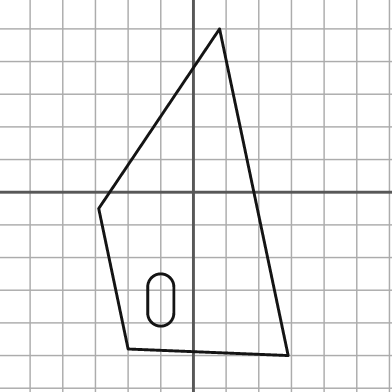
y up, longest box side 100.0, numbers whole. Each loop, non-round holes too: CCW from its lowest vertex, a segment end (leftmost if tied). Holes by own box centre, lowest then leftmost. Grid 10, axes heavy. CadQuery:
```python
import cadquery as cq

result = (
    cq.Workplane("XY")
    .moveTo(29.0, -50.0)
    .lineTo(8.0, 50.0)
    .lineTo(-29.0, -5.0)
    .lineTo(-20.0, -48.0)
    .close()
    .moveTo(-14.0, -37.0)
    .threePointArc((-10.0, -41.0), (-6.0, -37.0))
    .lineTo(-6.0, -29.0)
    .threePointArc((-10.0, -25.0), (-14.0, -29.0))
    .close()
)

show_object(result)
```